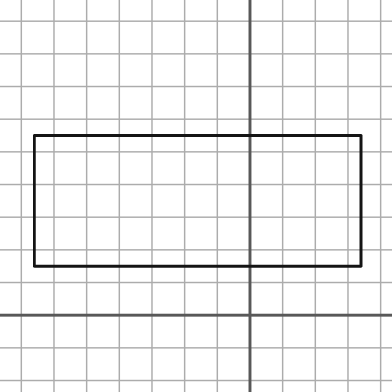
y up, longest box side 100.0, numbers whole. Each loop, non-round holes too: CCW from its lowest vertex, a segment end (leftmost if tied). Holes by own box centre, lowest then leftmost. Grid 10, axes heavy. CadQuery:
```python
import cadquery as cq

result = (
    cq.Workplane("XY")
    .moveTo(-66.0, 15.0)
    .lineTo(34.0, 15.0)
    .lineTo(34.0, 55.0)
    .lineTo(-66.0, 55.0)
    .close()
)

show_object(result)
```